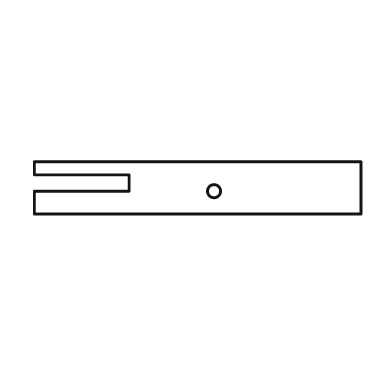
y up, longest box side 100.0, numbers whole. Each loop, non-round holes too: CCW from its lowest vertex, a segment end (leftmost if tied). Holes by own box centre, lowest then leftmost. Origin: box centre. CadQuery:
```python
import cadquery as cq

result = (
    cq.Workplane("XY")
    .moveTo(-50.0, -8.0)
    .lineTo(50.0, -8.0)
    .lineTo(50.0, 8.0)
    .lineTo(-50.0, 8.0)
    .lineTo(-50.0, 4.0)
    .lineTo(-21.0, 4.0)
    .lineTo(-21.0, -1.0)
    .lineTo(-50.0, -1.0)
    .close()
    .moveTo(5.0, -1.0)
    .circle(2.0)
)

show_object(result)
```